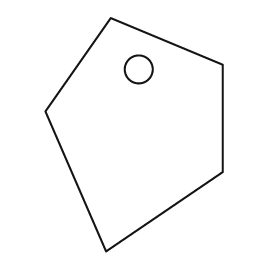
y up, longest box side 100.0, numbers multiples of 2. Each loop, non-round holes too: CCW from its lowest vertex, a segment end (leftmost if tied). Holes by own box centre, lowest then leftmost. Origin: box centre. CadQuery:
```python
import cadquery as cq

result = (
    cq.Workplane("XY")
    .moveTo(-12.0, -50.0)
    .lineTo(38.0, -16.0)
    .lineTo(38.0, 30.0)
    .lineTo(-10.0, 50.0)
    .lineTo(-38.0, 10.0)
    .close()
    .moveTo(2.0, 28.0)
    .circle(6.0)
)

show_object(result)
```